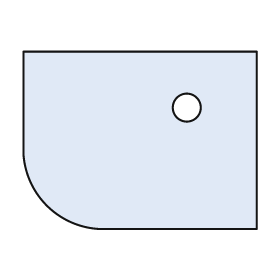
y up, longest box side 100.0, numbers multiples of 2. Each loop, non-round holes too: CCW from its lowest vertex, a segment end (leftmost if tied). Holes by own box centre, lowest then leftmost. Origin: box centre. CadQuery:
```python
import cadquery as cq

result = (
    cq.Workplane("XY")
    .moveTo(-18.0, -38.0)
    .lineTo(50.0, -38.0)
    .lineTo(50.0, 38.0)
    .lineTo(-50.0, 38.0)
    .lineTo(-50.0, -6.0)
    .threePointArc((-40.0, -28.0), (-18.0, -38.0))
    .close()
    .moveTo(20.0, 14.0)
    .circle(6.0)
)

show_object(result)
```